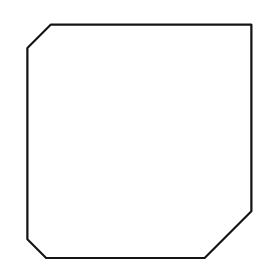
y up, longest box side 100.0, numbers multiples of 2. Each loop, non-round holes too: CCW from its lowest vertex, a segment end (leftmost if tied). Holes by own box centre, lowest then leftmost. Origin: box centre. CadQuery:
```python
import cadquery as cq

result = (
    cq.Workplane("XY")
    .moveTo(-40.0, -50.0)
    .lineTo(28.0, -50.0)
    .lineTo(48.0, -30.0)
    .lineTo(48.0, 50.0)
    .lineTo(-38.0, 50.0)
    .lineTo(-48.0, 40.0)
    .lineTo(-48.0, -42.0)
    .close()
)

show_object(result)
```